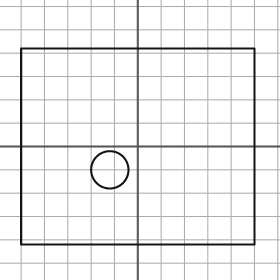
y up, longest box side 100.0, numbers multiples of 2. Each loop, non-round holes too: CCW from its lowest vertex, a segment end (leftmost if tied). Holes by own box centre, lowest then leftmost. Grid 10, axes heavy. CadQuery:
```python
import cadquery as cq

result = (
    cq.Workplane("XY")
    .moveTo(-50.0, -42.0)
    .lineTo(50.0, -42.0)
    .lineTo(50.0, 42.0)
    .lineTo(-50.0, 42.0)
    .close()
    .moveTo(-12.0, -10.0)
    .circle(8.0)
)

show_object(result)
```